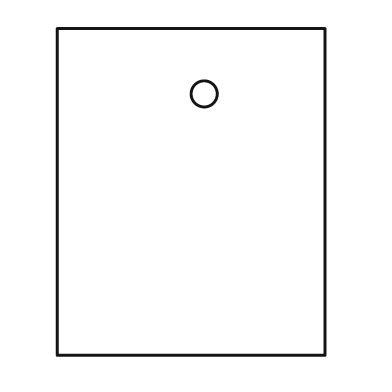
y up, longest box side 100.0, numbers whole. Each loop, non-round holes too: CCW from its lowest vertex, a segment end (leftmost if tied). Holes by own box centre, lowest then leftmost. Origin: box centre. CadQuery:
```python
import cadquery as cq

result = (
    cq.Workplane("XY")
    .moveTo(-41.0, -50.0)
    .lineTo(41.0, -50.0)
    .lineTo(41.0, 50.0)
    .lineTo(-41.0, 50.0)
    .close()
    .moveTo(4.0, 30.0)
    .circle(4.0)
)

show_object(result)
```